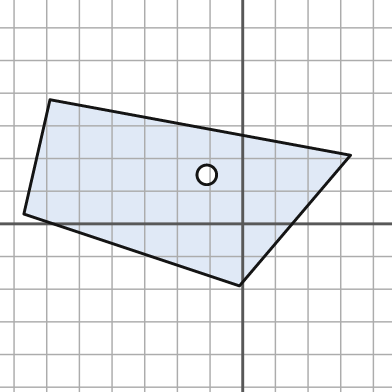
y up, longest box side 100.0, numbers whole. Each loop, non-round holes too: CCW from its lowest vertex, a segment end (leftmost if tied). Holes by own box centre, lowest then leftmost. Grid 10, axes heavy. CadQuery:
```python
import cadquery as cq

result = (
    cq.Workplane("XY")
    .moveTo(-1.0, -19.0)
    .lineTo(33.0, 21.0)
    .lineTo(-59.0, 38.0)
    .lineTo(-67.0, 3.0)
    .close()
    .moveTo(-11.0, 15.0)
    .circle(3.0)
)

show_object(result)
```